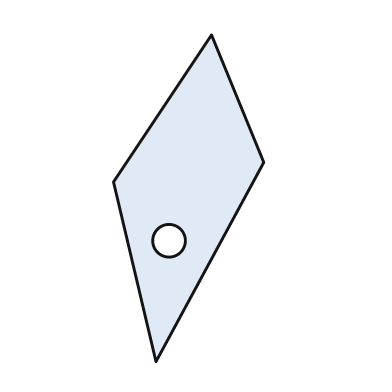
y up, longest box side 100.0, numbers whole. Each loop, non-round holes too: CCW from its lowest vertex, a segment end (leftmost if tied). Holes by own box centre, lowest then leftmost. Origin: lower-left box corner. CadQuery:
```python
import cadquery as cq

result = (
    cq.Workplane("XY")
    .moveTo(13.0, 0.0)
    .lineTo(46.0, 61.0)
    .lineTo(30.0, 100.0)
    .lineTo(0.0, 55.0)
    .close()
    .moveTo(17.0, 37.0)
    .circle(5.0)
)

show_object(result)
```